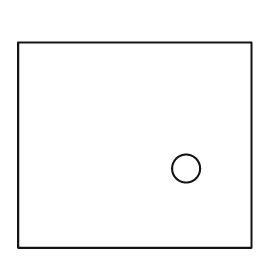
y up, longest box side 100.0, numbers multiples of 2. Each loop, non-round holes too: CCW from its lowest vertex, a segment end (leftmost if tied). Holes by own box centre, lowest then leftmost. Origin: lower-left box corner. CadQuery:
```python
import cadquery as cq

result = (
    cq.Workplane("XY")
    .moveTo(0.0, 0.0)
    .lineTo(100.0, 0.0)
    .lineTo(100.0, 88.0)
    .lineTo(0.0, 88.0)
    .close()
    .moveTo(72.0, 34.0)
    .circle(6.0)
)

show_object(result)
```